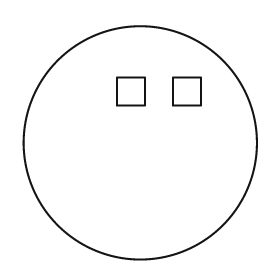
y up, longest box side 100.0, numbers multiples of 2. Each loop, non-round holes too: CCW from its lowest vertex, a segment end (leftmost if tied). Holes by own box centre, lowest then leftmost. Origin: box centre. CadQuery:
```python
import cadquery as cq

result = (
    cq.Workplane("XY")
    .moveTo(0.0, 0.0)
    .circle(50.0)
    .moveTo(-10.0, 16.0)
    .lineTo(2.0, 16.0)
    .lineTo(2.0, 28.0)
    .lineTo(-10.0, 28.0)
    .close()
    .moveTo(14.0, 16.0)
    .lineTo(26.0, 16.0)
    .lineTo(26.0, 28.0)
    .lineTo(14.0, 28.0)
    .close()
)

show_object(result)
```